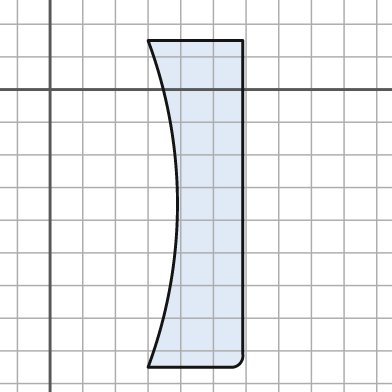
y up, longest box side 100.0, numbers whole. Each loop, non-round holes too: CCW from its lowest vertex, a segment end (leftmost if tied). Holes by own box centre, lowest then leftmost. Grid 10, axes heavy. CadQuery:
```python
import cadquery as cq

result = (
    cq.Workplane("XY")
    .moveTo(30.0, -85.0)
    .lineTo(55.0, -85.0)
    .threePointArc((58.0, -84.0), (59.0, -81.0))
    .lineTo(59.0, 15.0)
    .lineTo(30.0, 15.0)
    .threePointArc((39.0, -35.0), (30.0, -85.0))
    .close()
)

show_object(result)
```